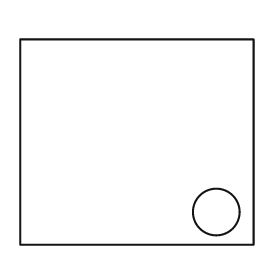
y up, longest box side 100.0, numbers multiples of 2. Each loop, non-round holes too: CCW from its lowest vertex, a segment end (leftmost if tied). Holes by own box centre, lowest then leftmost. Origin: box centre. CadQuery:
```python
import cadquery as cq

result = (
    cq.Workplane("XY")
    .moveTo(-50.0, -44.0)
    .lineTo(50.0, -44.0)
    .lineTo(50.0, 44.0)
    .lineTo(-50.0, 44.0)
    .close()
    .moveTo(34.0, -30.0)
    .circle(10.0)
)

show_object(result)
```